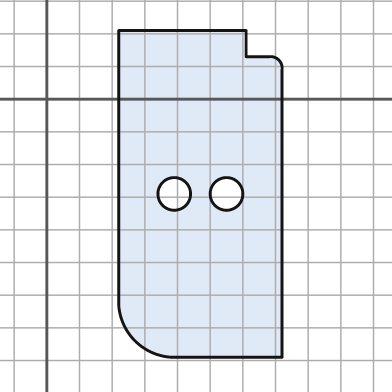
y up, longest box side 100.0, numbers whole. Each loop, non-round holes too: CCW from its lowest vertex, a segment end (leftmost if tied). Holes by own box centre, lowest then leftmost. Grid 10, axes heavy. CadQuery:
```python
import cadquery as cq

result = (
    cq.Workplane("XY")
    .moveTo(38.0, -79.0)
    .lineTo(72.0, -79.0)
    .lineTo(72.0, 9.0)
    .threePointArc((71.0, 12.0), (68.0, 13.0))
    .lineTo(61.0, 13.0)
    .lineTo(61.0, 21.0)
    .lineTo(22.0, 21.0)
    .lineTo(22.0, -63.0)
    .threePointArc((27.0, -74.0), (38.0, -79.0))
    .close()
    .moveTo(39.0, -29.0)
    .circle(5.0)
    .moveTo(55.0, -29.0)
    .circle(5.0)
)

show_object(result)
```